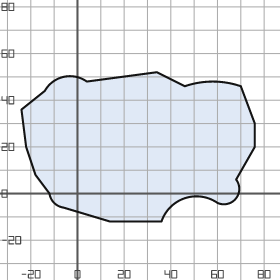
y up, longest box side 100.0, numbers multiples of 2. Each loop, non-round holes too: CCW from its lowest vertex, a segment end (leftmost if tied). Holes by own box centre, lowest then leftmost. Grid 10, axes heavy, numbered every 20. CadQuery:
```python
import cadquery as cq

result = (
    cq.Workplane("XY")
    .moveTo(14.0, -12.0)
    .lineTo(36.0, -12.0)
    .threePointArc((46.0, -2.0), (60.0, -4.0))
    .threePointArc((68.0, -2.0), (68.0, 6.0))
    .lineTo(76.0, 20.0)
    .lineTo(76.0, 30.0)
    .lineTo(70.0, 46.0)
    .threePointArc((58.0, 48.0), (46.0, 46.0))
    .lineTo(34.0, 52.0)
    .lineTo(4.0, 48.0)
    .threePointArc((-6.0, 50.0), (-14.0, 44.0))
    .lineTo(-24.0, 36.0)
    .lineTo(-22.0, 20.0)
    .lineTo(-18.0, 8.0)
    .lineTo(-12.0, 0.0)
    .threePointArc((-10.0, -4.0), (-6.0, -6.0))
    .close()
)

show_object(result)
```